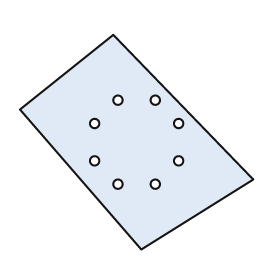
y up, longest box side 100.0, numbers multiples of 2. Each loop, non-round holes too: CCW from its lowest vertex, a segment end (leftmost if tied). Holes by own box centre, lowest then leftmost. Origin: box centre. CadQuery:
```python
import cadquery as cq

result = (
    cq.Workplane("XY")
    .moveTo(2.0, -46.0)
    .lineTo(50.0, -16.0)
    .lineTo(-10.0, 46.0)
    .lineTo(-50.0, 14.0)
    .close()
    .moveTo(-8.0, -18.0)
    .circle(2.0)
    .moveTo(8.0, -18.0)
    .circle(2.0)
    .moveTo(-18.0, -8.0)
    .circle(2.0)
    .moveTo(18.0, -8.0)
    .circle(2.0)
    .moveTo(-18.0, 8.0)
    .circle(2.0)
    .moveTo(18.0, 8.0)
    .circle(2.0)
    .moveTo(-8.0, 18.0)
    .circle(2.0)
    .moveTo(8.0, 18.0)
    .circle(2.0)
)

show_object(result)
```